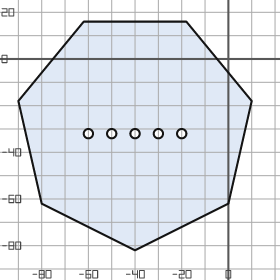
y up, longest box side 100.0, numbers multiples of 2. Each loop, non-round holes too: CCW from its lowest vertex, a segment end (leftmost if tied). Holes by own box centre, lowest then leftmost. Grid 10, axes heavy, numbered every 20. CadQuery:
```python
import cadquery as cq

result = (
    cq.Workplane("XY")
    .moveTo(-40.0, -82.0)
    .lineTo(0.0, -62.0)
    .lineTo(10.0, -18.0)
    .lineTo(-18.0, 16.0)
    .lineTo(-62.0, 16.0)
    .lineTo(-90.0, -18.0)
    .lineTo(-80.0, -62.0)
    .close()
    .moveTo(-60.0, -32.0)
    .circle(2.0)
    .moveTo(-50.0, -32.0)
    .circle(2.0)
    .moveTo(-40.0, -32.0)
    .circle(2.0)
    .moveTo(-30.0, -32.0)
    .circle(2.0)
    .moveTo(-20.0, -32.0)
    .circle(2.0)
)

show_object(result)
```